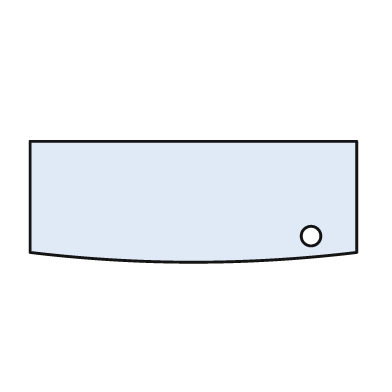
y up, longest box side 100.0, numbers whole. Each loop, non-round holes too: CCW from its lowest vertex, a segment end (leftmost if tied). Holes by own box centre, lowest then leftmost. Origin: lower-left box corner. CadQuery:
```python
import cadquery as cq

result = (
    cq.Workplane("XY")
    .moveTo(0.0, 3.0)
    .threePointArc((50.0, 0.0), (100.0, 3.0))
    .lineTo(100.0, 37.0)
    .lineTo(0.0, 37.0)
    .close()
    .moveTo(86.0, 8.0)
    .circle(3.0)
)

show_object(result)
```